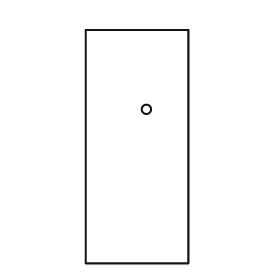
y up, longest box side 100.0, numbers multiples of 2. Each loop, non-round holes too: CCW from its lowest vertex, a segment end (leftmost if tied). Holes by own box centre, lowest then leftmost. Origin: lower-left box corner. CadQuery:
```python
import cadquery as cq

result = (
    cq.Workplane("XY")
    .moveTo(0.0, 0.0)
    .lineTo(44.0, 0.0)
    .lineTo(44.0, 100.0)
    .lineTo(0.0, 100.0)
    .close()
    .moveTo(26.0, 66.0)
    .circle(2.0)
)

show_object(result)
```